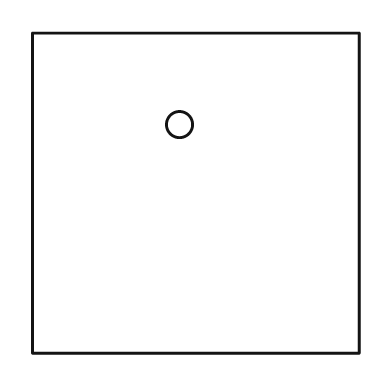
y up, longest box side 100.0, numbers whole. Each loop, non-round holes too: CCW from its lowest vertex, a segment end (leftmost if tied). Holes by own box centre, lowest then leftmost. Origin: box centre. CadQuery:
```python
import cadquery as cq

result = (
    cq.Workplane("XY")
    .moveTo(-50.0, -49.0)
    .lineTo(50.0, -49.0)
    .lineTo(50.0, 49.0)
    .lineTo(-50.0, 49.0)
    .close()
    .moveTo(-5.0, 21.0)
    .circle(4.0)
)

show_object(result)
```